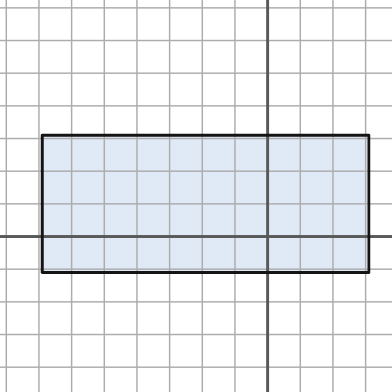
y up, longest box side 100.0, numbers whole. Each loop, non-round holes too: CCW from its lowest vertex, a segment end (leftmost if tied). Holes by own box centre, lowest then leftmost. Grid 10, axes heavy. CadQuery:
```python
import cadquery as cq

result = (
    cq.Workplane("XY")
    .moveTo(-69.0, -11.0)
    .lineTo(31.0, -11.0)
    .lineTo(31.0, 31.0)
    .lineTo(-69.0, 31.0)
    .close()
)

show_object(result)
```